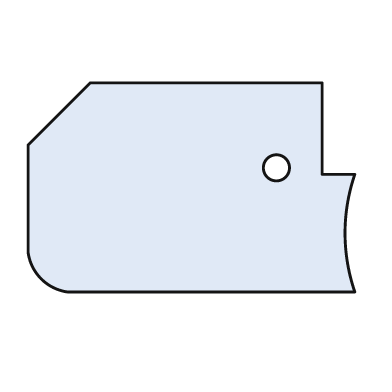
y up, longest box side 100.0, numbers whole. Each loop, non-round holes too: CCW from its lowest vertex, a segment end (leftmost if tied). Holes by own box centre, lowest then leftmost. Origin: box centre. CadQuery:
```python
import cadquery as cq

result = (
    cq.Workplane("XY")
    .moveTo(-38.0, -32.0)
    .lineTo(50.0, -32.0)
    .threePointArc((47.0, -14.0), (50.0, 4.0))
    .lineTo(40.0, 4.0)
    .lineTo(40.0, 32.0)
    .lineTo(-31.0, 32.0)
    .lineTo(-50.0, 13.0)
    .lineTo(-50.0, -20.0)
    .threePointArc((-46.0, -28.0), (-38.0, -32.0))
    .close()
    .moveTo(26.0, 6.0)
    .circle(4.0)
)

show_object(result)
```